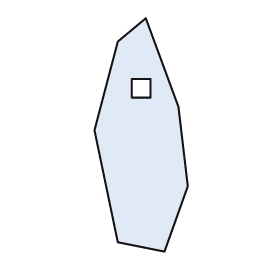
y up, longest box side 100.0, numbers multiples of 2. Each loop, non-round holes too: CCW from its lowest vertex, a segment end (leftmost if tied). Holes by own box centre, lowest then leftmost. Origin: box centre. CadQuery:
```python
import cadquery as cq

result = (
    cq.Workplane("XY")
    .moveTo(10.0, -50.0)
    .lineTo(20.0, -22.0)
    .lineTo(16.0, 12.0)
    .lineTo(2.0, 50.0)
    .lineTo(-10.0, 40.0)
    .lineTo(-20.0, 2.0)
    .lineTo(-10.0, -46.0)
    .close()
    .moveTo(-4.0, 16.0)
    .lineTo(4.0, 16.0)
    .lineTo(4.0, 24.0)
    .lineTo(-4.0, 24.0)
    .close()
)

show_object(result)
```